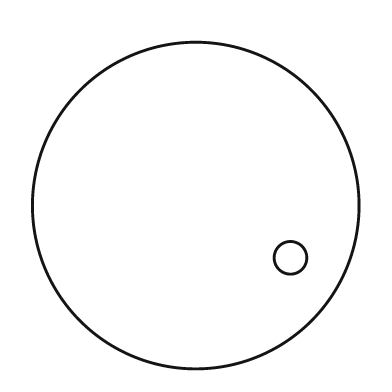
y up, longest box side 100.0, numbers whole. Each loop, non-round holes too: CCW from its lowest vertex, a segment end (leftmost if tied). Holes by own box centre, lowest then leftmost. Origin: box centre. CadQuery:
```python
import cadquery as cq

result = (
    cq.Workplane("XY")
    .moveTo(0.0, 0.0)
    .circle(50.0)
    .moveTo(29.0, -16.0)
    .circle(5.0)
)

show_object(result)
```